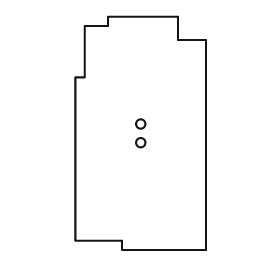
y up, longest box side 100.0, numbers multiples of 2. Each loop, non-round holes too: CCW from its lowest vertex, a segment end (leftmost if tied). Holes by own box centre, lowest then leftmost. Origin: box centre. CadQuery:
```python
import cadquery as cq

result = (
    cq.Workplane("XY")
    .moveTo(-8.0, -50.0)
    .lineTo(28.0, -50.0)
    .lineTo(28.0, 40.0)
    .lineTo(16.0, 40.0)
    .lineTo(16.0, 50.0)
    .lineTo(-14.0, 50.0)
    .lineTo(-14.0, 46.0)
    .lineTo(-24.0, 46.0)
    .lineTo(-24.0, 24.0)
    .lineTo(-28.0, 24.0)
    .lineTo(-28.0, -46.0)
    .lineTo(-8.0, -46.0)
    .close()
    .moveTo(0.0, -4.0)
    .circle(2.0)
    .moveTo(0.0, 4.0)
    .circle(2.0)
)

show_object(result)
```